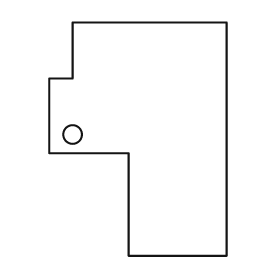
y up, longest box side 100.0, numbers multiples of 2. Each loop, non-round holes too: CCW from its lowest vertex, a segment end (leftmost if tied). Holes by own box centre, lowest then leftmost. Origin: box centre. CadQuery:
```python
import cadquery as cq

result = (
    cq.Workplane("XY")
    .moveTo(-4.0, -50.0)
    .lineTo(38.0, -50.0)
    .lineTo(38.0, 50.0)
    .lineTo(-28.0, 50.0)
    .lineTo(-28.0, 26.0)
    .lineTo(-38.0, 26.0)
    .lineTo(-38.0, -6.0)
    .lineTo(-4.0, -6.0)
    .close()
    .moveTo(-28.0, 2.0)
    .circle(4.0)
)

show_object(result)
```